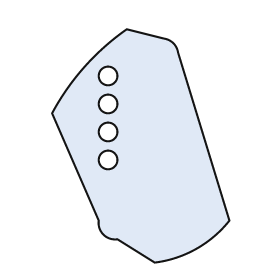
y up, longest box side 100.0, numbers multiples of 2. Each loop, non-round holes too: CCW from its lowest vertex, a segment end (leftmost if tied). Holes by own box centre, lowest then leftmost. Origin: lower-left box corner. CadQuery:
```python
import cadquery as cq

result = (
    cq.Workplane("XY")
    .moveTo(44.0, 0.0)
    .threePointArc((62.0, 6.0), (76.0, 18.0))
    .lineTo(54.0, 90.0)
    .threePointArc((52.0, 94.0), (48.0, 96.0))
    .lineTo(32.0, 100.0)
    .threePointArc((14.0, 84.0), (0.0, 64.0))
    .lineTo(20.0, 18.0)
    .threePointArc((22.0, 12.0), (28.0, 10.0))
    .close()
    .moveTo(24.0, 44.0)
    .circle(4.0)
    .moveTo(24.0, 56.0)
    .circle(4.0)
    .moveTo(24.0, 68.0)
    .circle(4.0)
    .moveTo(24.0, 80.0)
    .circle(4.0)
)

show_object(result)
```